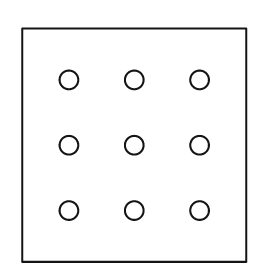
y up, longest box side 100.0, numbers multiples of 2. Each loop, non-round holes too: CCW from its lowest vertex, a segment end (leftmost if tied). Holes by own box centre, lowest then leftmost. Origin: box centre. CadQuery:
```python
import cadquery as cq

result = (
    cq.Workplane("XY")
    .moveTo(-48.0, -50.0)
    .lineTo(48.0, -50.0)
    .lineTo(48.0, 50.0)
    .lineTo(-48.0, 50.0)
    .close()
    .moveTo(-28.0, -28.0)
    .circle(4.0)
    .moveTo(0.0, -28.0)
    .circle(4.0)
    .moveTo(28.0, -28.0)
    .circle(4.0)
    .moveTo(-28.0, 0.0)
    .circle(4.0)
    .moveTo(0.0, 0.0)
    .circle(4.0)
    .moveTo(28.0, 0.0)
    .circle(4.0)
    .moveTo(-28.0, 28.0)
    .circle(4.0)
    .moveTo(0.0, 28.0)
    .circle(4.0)
    .moveTo(28.0, 28.0)
    .circle(4.0)
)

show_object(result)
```